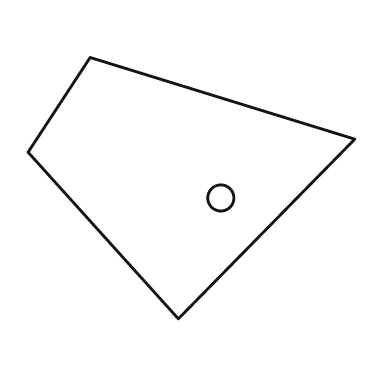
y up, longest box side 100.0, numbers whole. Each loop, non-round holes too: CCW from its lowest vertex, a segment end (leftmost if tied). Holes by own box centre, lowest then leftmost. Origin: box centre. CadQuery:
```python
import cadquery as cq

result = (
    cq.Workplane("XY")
    .moveTo(-4.0, -40.0)
    .lineTo(50.0, 15.0)
    .lineTo(-31.0, 40.0)
    .lineTo(-50.0, 11.0)
    .close()
    .moveTo(9.0, -3.0)
    .circle(4.0)
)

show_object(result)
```